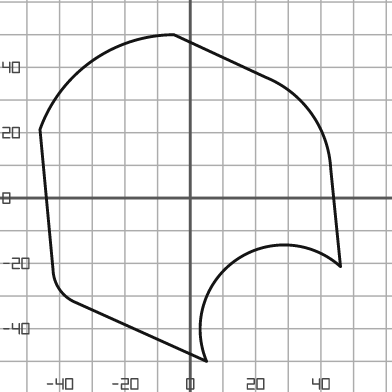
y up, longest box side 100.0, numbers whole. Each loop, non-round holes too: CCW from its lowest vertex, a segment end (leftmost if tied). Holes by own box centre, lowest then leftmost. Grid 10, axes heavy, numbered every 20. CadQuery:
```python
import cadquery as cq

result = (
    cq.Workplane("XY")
    .moveTo(5.0, -50.0)
    .threePointArc((14.0, -19.0), (46.0, -21.0))
    .lineTo(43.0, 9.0)
    .threePointArc((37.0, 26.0), (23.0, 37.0))
    .lineTo(-5.0, 50.0)
    .threePointArc((-30.0, 42.0), (-46.0, 21.0))
    .lineTo(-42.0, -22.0)
    .threePointArc((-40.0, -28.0), (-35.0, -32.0))
    .close()
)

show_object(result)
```